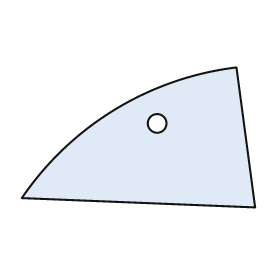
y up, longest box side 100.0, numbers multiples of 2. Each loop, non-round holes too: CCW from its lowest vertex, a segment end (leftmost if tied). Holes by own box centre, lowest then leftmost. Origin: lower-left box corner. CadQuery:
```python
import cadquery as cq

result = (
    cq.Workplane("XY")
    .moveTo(100.0, 0.0)
    .lineTo(92.0, 60.0)
    .threePointArc((40.0, 42.0), (0.0, 4.0))
    .close()
    .moveTo(58.0, 36.0)
    .circle(4.0)
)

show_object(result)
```